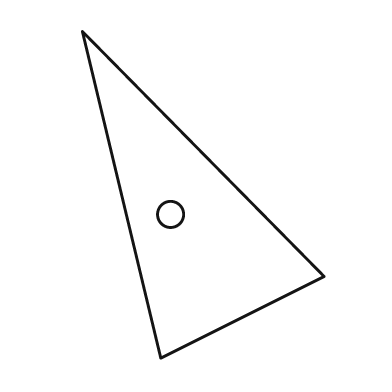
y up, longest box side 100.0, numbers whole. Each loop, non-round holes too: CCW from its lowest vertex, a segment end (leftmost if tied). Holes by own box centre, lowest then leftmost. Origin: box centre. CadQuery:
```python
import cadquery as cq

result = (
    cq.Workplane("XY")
    .moveTo(-13.0, -50.0)
    .lineTo(37.0, -25.0)
    .lineTo(-37.0, 50.0)
    .close()
    .moveTo(-10.0, -6.0)
    .circle(4.0)
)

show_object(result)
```